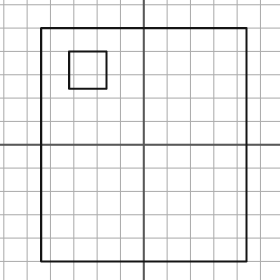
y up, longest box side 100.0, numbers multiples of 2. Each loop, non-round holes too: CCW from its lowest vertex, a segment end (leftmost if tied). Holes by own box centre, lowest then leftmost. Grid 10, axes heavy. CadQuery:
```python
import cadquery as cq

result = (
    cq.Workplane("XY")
    .moveTo(-44.0, -50.0)
    .lineTo(44.0, -50.0)
    .lineTo(44.0, 50.0)
    .lineTo(-44.0, 50.0)
    .close()
    .moveTo(-32.0, 24.0)
    .lineTo(-16.0, 24.0)
    .lineTo(-16.0, 40.0)
    .lineTo(-32.0, 40.0)
    .close()
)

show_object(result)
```